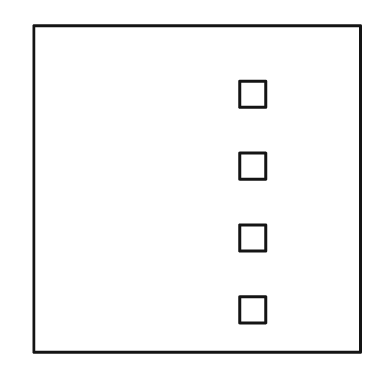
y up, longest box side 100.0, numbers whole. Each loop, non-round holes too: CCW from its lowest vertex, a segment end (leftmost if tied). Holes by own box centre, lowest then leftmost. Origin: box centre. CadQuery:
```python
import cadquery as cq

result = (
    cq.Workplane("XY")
    .moveTo(-50.0, -50.0)
    .lineTo(50.0, -50.0)
    .lineTo(50.0, 50.0)
    .lineTo(-50.0, 50.0)
    .close()
    .moveTo(13.0, -41.0)
    .lineTo(21.0, -41.0)
    .lineTo(21.0, -33.0)
    .lineTo(13.0, -33.0)
    .close()
    .moveTo(13.0, -19.0)
    .lineTo(21.0, -19.0)
    .lineTo(21.0, -11.0)
    .lineTo(13.0, -11.0)
    .close()
    .moveTo(13.0, 3.0)
    .lineTo(21.0, 3.0)
    .lineTo(21.0, 11.0)
    .lineTo(13.0, 11.0)
    .close()
    .moveTo(13.0, 25.0)
    .lineTo(21.0, 25.0)
    .lineTo(21.0, 33.0)
    .lineTo(13.0, 33.0)
    .close()
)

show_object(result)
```